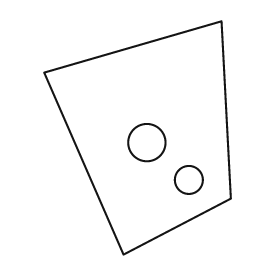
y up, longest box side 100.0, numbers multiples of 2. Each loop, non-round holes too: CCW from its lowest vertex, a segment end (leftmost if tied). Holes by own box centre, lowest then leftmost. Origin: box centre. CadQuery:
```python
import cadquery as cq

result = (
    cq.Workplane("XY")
    .moveTo(-6.0, -50.0)
    .lineTo(40.0, -26.0)
    .lineTo(36.0, 50.0)
    .lineTo(-40.0, 28.0)
    .close()
    .moveTo(22.0, -18.0)
    .circle(6.0)
    .moveTo(4.0, -2.0)
    .circle(8.0)
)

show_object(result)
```